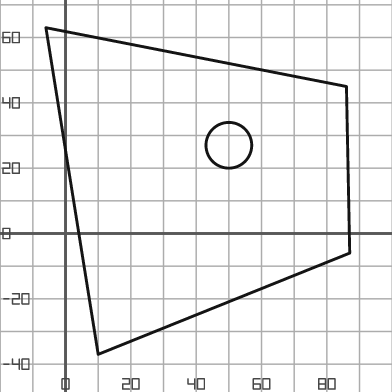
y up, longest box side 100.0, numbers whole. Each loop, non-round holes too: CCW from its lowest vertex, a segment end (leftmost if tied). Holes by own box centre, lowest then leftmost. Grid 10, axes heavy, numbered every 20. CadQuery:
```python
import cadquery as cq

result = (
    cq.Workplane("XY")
    .moveTo(10.0, -37.0)
    .lineTo(87.0, -6.0)
    .lineTo(86.0, 45.0)
    .lineTo(-6.0, 63.0)
    .close()
    .moveTo(50.0, 27.0)
    .circle(7.0)
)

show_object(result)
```